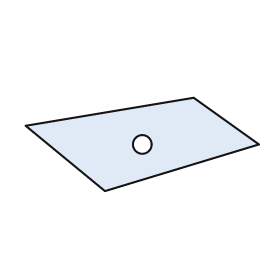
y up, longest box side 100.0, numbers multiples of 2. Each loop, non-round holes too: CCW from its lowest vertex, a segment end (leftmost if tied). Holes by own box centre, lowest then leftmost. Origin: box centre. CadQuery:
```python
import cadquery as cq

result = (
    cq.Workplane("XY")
    .moveTo(-16.0, -20.0)
    .lineTo(50.0, 0.0)
    .lineTo(22.0, 20.0)
    .lineTo(-50.0, 8.0)
    .close()
    .moveTo(0.0, 0.0)
    .circle(4.0)
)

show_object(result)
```